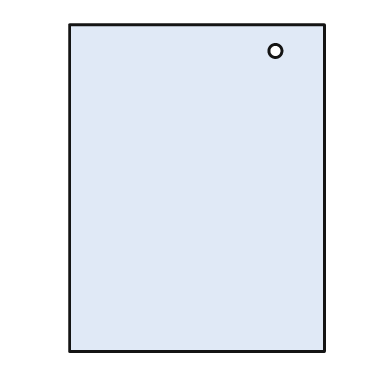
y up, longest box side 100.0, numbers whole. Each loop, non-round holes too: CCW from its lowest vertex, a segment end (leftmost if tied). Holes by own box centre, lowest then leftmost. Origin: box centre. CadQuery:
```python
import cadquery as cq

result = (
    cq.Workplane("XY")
    .moveTo(-39.0, -50.0)
    .lineTo(39.0, -50.0)
    .lineTo(39.0, 50.0)
    .lineTo(-39.0, 50.0)
    .close()
    .moveTo(24.0, 42.0)
    .circle(2.0)
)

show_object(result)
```